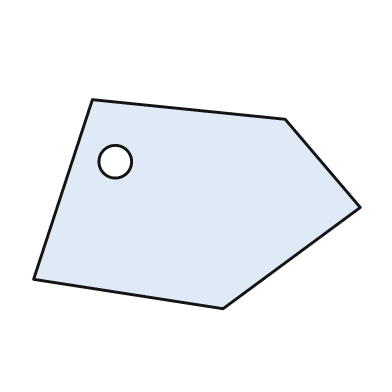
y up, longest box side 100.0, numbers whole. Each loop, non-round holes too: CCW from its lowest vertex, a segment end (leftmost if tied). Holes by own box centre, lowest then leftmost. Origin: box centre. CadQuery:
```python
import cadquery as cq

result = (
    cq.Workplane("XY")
    .moveTo(8.0, -32.0)
    .lineTo(50.0, -1.0)
    .lineTo(27.0, 26.0)
    .lineTo(-32.0, 32.0)
    .lineTo(-50.0, -23.0)
    .close()
    .moveTo(-25.0, 13.0)
    .circle(5.0)
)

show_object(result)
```